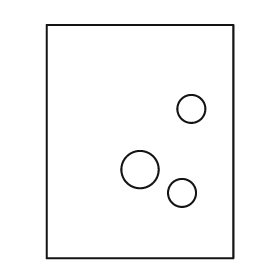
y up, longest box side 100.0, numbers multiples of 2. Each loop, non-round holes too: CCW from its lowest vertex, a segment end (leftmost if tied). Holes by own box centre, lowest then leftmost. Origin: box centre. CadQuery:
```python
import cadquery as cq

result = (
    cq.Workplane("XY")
    .moveTo(-40.0, -50.0)
    .lineTo(40.0, -50.0)
    .lineTo(40.0, 50.0)
    .lineTo(-40.0, 50.0)
    .close()
    .moveTo(18.0, -22.0)
    .circle(6.0)
    .moveTo(0.0, -12.0)
    .circle(8.0)
    .moveTo(22.0, 14.0)
    .circle(6.0)
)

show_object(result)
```